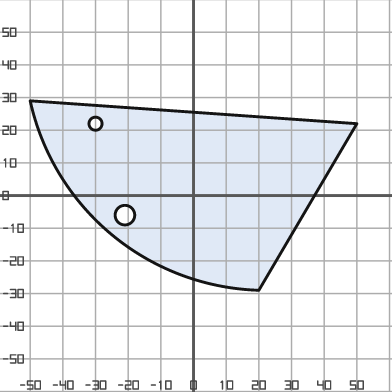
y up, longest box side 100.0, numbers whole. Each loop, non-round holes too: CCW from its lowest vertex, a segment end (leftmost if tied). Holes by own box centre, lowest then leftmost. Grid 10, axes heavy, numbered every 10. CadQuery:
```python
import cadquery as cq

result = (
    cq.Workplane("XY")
    .moveTo(20.0, -29.0)
    .lineTo(50.0, 22.0)
    .lineTo(-50.0, 29.0)
    .threePointArc((-25.0, -12.0), (20.0, -29.0))
    .close()
    .moveTo(-21.0, -6.0)
    .circle(3.0)
    .moveTo(-30.0, 22.0)
    .circle(2.0)
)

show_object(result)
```